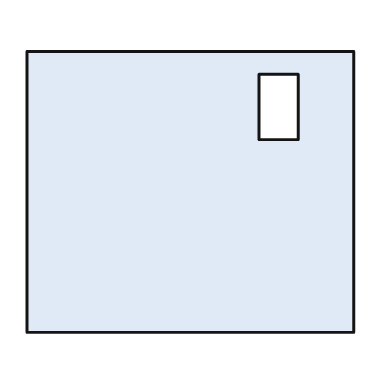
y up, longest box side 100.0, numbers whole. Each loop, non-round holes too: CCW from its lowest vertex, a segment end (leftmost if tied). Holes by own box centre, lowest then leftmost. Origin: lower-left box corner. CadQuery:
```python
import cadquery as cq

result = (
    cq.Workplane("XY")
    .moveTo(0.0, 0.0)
    .lineTo(100.0, 0.0)
    .lineTo(100.0, 86.0)
    .lineTo(0.0, 86.0)
    .close()
    .moveTo(71.0, 59.0)
    .lineTo(83.0, 59.0)
    .lineTo(83.0, 79.0)
    .lineTo(71.0, 79.0)
    .close()
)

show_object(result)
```